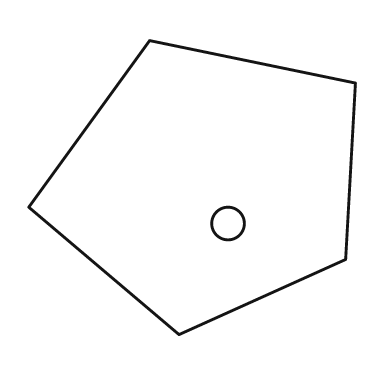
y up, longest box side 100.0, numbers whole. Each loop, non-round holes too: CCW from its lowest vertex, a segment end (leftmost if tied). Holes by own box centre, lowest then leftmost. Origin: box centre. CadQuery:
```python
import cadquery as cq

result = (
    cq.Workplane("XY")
    .moveTo(-4.0, -45.0)
    .lineTo(47.0, -22.0)
    .lineTo(50.0, 32.0)
    .lineTo(-13.0, 45.0)
    .lineTo(-50.0, -6.0)
    .close()
    .moveTo(11.0, -11.0)
    .circle(5.0)
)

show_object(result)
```